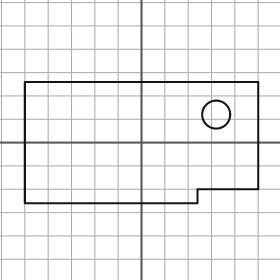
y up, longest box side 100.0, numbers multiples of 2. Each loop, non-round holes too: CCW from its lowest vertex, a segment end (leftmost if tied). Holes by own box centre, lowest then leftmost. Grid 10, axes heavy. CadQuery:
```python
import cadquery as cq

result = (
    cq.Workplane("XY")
    .moveTo(-50.0, -26.0)
    .lineTo(24.0, -26.0)
    .lineTo(24.0, -20.0)
    .lineTo(50.0, -20.0)
    .lineTo(50.0, 26.0)
    .lineTo(-50.0, 26.0)
    .close()
    .moveTo(32.0, 12.0)
    .circle(6.0)
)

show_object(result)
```